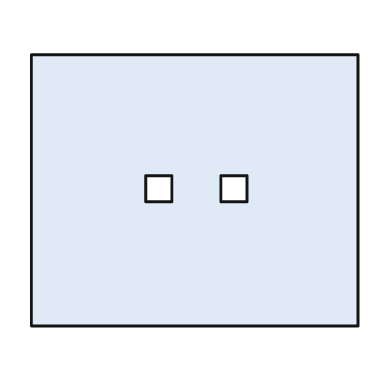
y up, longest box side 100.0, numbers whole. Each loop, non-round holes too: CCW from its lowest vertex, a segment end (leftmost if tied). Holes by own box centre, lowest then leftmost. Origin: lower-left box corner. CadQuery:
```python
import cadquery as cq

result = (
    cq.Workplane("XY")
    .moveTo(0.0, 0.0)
    .lineTo(100.0, 0.0)
    .lineTo(100.0, 83.0)
    .lineTo(0.0, 83.0)
    .close()
    .moveTo(35.0, 38.0)
    .lineTo(43.0, 38.0)
    .lineTo(43.0, 46.0)
    .lineTo(35.0, 46.0)
    .close()
    .moveTo(58.0, 38.0)
    .lineTo(66.0, 38.0)
    .lineTo(66.0, 46.0)
    .lineTo(58.0, 46.0)
    .close()
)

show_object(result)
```